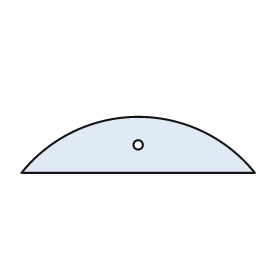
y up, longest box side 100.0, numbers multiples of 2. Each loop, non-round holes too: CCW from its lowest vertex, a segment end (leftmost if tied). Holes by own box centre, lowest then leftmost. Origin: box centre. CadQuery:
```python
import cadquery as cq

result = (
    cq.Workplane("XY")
    .moveTo(-50.0, -12.0)
    .lineTo(50.0, -12.0)
    .threePointArc((0.0, 12.0), (-50.0, -12.0))
    .close()
    .moveTo(0.0, 0.0)
    .circle(2.0)
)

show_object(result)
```